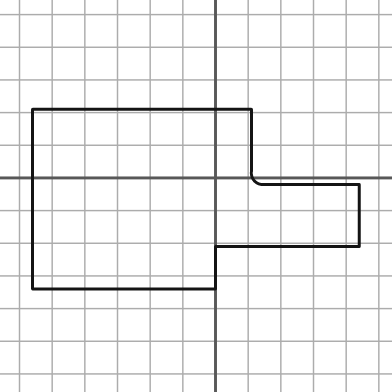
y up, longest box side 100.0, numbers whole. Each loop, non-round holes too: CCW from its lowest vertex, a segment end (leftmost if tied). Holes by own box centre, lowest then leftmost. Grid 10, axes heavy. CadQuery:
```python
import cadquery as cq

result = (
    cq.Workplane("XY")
    .moveTo(-56.0, -34.0)
    .lineTo(0.0, -34.0)
    .lineTo(0.0, -21.0)
    .lineTo(44.0, -21.0)
    .lineTo(44.0, -2.0)
    .lineTo(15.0, -2.0)
    .threePointArc((12.0, -1.0), (11.0, 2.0))
    .lineTo(11.0, 21.0)
    .lineTo(-56.0, 21.0)
    .close()
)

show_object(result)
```